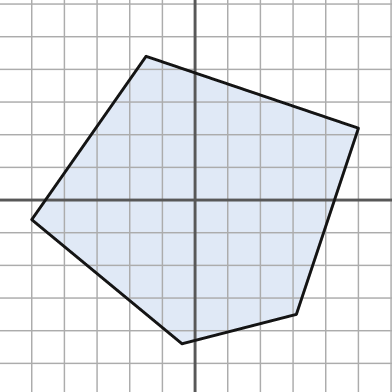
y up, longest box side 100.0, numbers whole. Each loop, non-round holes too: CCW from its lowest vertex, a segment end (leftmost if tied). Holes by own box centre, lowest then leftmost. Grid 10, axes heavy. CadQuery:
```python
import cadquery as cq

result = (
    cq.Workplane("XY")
    .moveTo(-4.0, -44.0)
    .lineTo(31.0, -35.0)
    .lineTo(50.0, 22.0)
    .lineTo(-15.0, 44.0)
    .lineTo(-50.0, -6.0)
    .close()
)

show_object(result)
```